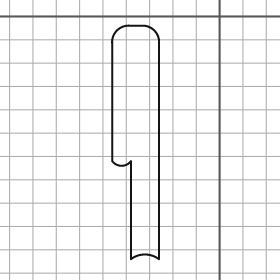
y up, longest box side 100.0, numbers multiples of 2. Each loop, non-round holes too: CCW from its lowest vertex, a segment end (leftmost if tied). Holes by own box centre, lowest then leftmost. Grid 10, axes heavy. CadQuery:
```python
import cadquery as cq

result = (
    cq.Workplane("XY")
    .moveTo(-38.0, -104.0)
    .threePointArc((-32.0, -102.0), (-26.0, -104.0))
    .lineTo(-26.0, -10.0)
    .threePointArc((-28.0, -6.0), (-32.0, -4.0))
    .lineTo(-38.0, -4.0)
    .threePointArc((-44.0, -6.0), (-46.0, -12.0))
    .lineTo(-46.0, -62.0)
    .threePointArc((-42.0, -64.0), (-38.0, -62.0))
    .close()
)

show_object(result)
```